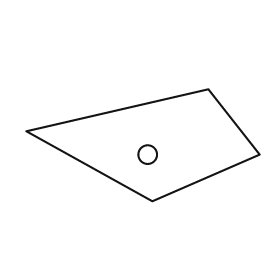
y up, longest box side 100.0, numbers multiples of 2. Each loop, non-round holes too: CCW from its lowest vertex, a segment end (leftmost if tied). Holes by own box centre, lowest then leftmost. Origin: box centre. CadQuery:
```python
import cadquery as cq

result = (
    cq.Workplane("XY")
    .moveTo(4.0, -24.0)
    .lineTo(50.0, -4.0)
    .lineTo(28.0, 24.0)
    .lineTo(-50.0, 6.0)
    .close()
    .moveTo(2.0, -4.0)
    .circle(4.0)
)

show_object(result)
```